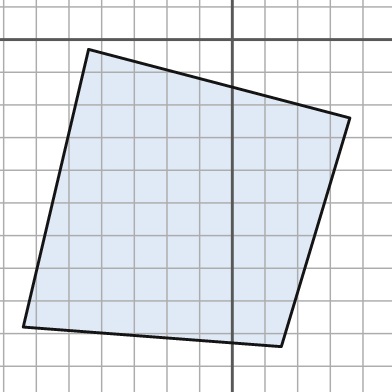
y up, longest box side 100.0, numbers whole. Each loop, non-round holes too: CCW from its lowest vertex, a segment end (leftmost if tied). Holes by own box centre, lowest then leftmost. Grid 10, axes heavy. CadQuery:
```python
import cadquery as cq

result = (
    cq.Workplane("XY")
    .moveTo(15.0, -94.0)
    .lineTo(36.0, -24.0)
    .lineTo(-44.0, -3.0)
    .lineTo(-64.0, -88.0)
    .close()
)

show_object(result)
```